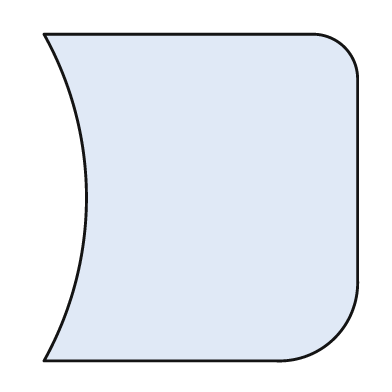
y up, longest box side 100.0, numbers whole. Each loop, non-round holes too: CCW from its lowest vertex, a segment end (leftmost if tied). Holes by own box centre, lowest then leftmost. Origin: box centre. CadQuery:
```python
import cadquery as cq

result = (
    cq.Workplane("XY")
    .moveTo(-48.0, -50.0)
    .lineTo(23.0, -50.0)
    .threePointArc((41.0, -43.0), (48.0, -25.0))
    .lineTo(48.0, 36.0)
    .threePointArc((44.0, 46.0), (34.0, 50.0))
    .lineTo(-48.0, 50.0)
    .threePointArc((-35.0, 0.0), (-48.0, -50.0))
    .close()
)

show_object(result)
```